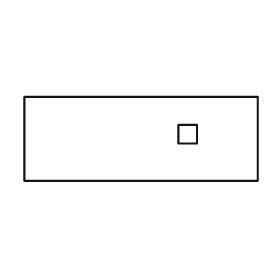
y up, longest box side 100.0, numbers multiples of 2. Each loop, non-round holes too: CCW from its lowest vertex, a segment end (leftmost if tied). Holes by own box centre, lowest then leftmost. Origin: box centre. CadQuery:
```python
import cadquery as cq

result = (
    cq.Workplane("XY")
    .moveTo(-50.0, -18.0)
    .lineTo(50.0, -18.0)
    .lineTo(50.0, 18.0)
    .lineTo(-50.0, 18.0)
    .close()
    .moveTo(16.0, -2.0)
    .lineTo(24.0, -2.0)
    .lineTo(24.0, 6.0)
    .lineTo(16.0, 6.0)
    .close()
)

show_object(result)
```